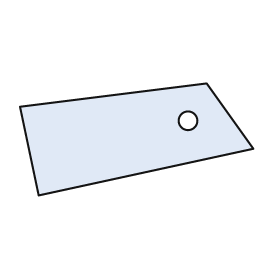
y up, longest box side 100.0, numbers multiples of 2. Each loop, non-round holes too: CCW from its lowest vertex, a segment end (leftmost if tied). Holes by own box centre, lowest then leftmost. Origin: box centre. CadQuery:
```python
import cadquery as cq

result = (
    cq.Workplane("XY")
    .moveTo(-42.0, -24.0)
    .lineTo(50.0, -4.0)
    .lineTo(30.0, 24.0)
    .lineTo(-50.0, 14.0)
    .close()
    .moveTo(22.0, 8.0)
    .circle(4.0)
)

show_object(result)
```